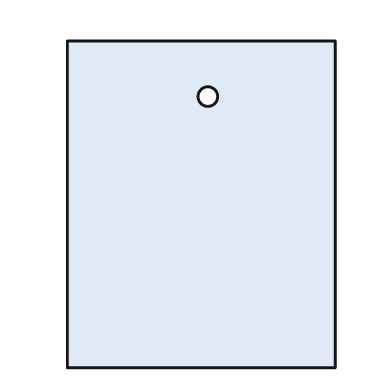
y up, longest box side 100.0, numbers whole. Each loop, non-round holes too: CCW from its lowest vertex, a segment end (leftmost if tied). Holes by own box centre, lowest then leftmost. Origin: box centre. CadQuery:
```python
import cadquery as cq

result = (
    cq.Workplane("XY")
    .moveTo(-41.0, -50.0)
    .lineTo(41.0, -50.0)
    .lineTo(41.0, 50.0)
    .lineTo(-41.0, 50.0)
    .close()
    .moveTo(2.0, 33.0)
    .circle(3.0)
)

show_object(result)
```